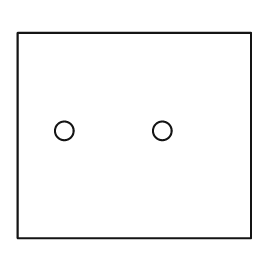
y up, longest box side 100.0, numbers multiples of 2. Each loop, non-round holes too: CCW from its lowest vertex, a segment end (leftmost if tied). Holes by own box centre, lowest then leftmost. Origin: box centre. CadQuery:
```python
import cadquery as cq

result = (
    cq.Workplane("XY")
    .moveTo(-50.0, -44.0)
    .lineTo(50.0, -44.0)
    .lineTo(50.0, 44.0)
    .lineTo(-50.0, 44.0)
    .close()
    .moveTo(-30.0, 2.0)
    .circle(4.0)
    .moveTo(12.0, 2.0)
    .circle(4.0)
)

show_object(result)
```